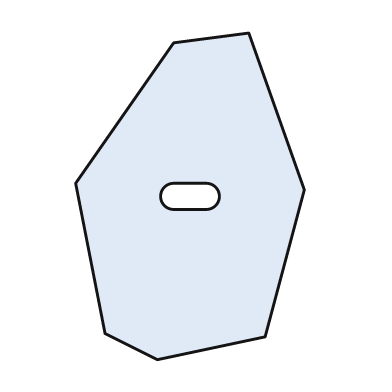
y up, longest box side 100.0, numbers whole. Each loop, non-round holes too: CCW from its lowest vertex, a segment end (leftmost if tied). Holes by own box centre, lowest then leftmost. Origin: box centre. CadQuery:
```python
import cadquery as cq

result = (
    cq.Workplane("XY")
    .moveTo(-10.0, -50.0)
    .lineTo(23.0, -43.0)
    .lineTo(35.0, 2.0)
    .lineTo(18.0, 50.0)
    .lineTo(-5.0, 47.0)
    .lineTo(-35.0, 4.0)
    .lineTo(-26.0, -42.0)
    .close()
    .moveTo(-5.0, -4.0)
    .lineTo(5.0, -4.0)
    .threePointArc((9.0, 0.0), (5.0, 4.0))
    .lineTo(-5.0, 4.0)
    .threePointArc((-9.0, 0.0), (-5.0, -4.0))
    .close()
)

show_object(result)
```